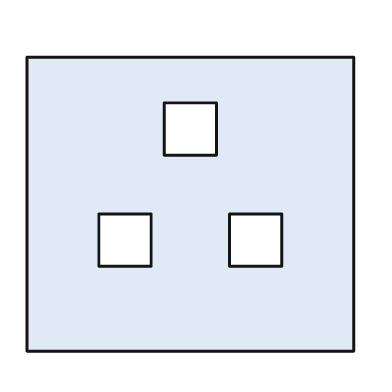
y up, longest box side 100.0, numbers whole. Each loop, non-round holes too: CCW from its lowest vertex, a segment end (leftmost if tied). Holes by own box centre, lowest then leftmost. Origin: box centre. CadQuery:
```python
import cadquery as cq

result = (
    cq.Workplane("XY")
    .moveTo(-50.0, -45.0)
    .lineTo(50.0, -45.0)
    .lineTo(50.0, 45.0)
    .lineTo(-50.0, 45.0)
    .close()
    .moveTo(-28.0, -19.0)
    .lineTo(-12.0, -19.0)
    .lineTo(-12.0, -3.0)
    .lineTo(-28.0, -3.0)
    .close()
    .moveTo(12.0, -19.0)
    .lineTo(28.0, -19.0)
    .lineTo(28.0, -3.0)
    .lineTo(12.0, -3.0)
    .close()
    .moveTo(-8.0, 15.0)
    .lineTo(8.0, 15.0)
    .lineTo(8.0, 31.0)
    .lineTo(-8.0, 31.0)
    .close()
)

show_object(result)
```